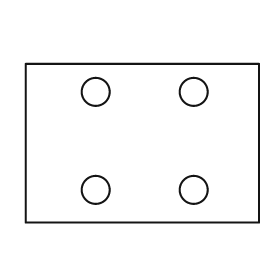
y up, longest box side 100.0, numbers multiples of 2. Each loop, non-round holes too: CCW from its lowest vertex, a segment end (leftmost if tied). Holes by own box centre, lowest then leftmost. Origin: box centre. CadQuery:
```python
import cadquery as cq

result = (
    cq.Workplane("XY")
    .moveTo(-50.0, -34.0)
    .lineTo(50.0, -34.0)
    .lineTo(50.0, 34.0)
    .lineTo(-50.0, 34.0)
    .close()
    .moveTo(-20.0, -20.0)
    .circle(6.0)
    .moveTo(22.0, -20.0)
    .circle(6.0)
    .moveTo(-20.0, 22.0)
    .circle(6.0)
    .moveTo(22.0, 22.0)
    .circle(6.0)
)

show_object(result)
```